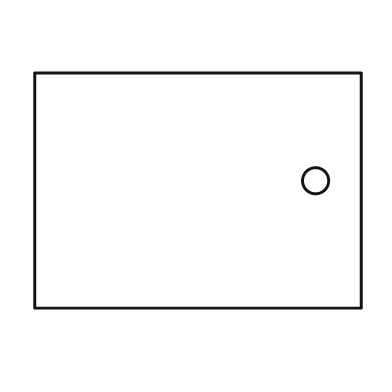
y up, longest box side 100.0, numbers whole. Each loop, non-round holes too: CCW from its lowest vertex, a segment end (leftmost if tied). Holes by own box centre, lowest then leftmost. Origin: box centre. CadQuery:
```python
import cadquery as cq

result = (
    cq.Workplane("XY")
    .moveTo(-50.0, -36.0)
    .lineTo(50.0, -36.0)
    .lineTo(50.0, 36.0)
    .lineTo(-50.0, 36.0)
    .close()
    .moveTo(36.0, 3.0)
    .circle(4.0)
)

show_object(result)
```